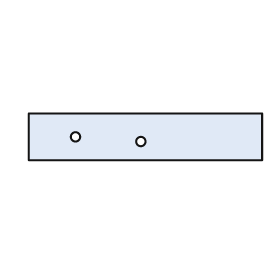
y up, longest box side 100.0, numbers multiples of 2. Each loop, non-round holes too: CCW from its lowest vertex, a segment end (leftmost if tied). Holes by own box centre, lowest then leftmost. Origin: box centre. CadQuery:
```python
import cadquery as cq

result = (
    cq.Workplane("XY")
    .moveTo(-50.0, -10.0)
    .lineTo(50.0, -10.0)
    .lineTo(50.0, 10.0)
    .lineTo(-50.0, 10.0)
    .close()
    .moveTo(-2.0, -2.0)
    .circle(2.0)
    .moveTo(-30.0, 0.0)
    .circle(2.0)
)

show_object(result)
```